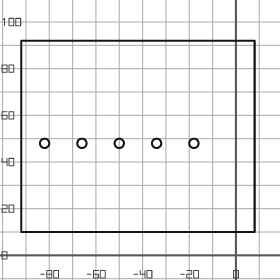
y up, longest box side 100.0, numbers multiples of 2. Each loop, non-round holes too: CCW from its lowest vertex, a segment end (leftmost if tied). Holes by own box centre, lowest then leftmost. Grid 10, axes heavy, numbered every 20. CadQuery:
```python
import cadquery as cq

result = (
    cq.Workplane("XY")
    .moveTo(-92.0, 10.0)
    .lineTo(8.0, 10.0)
    .lineTo(8.0, 92.0)
    .lineTo(-92.0, 92.0)
    .close()
    .moveTo(-82.0, 48.0)
    .circle(2.0)
    .moveTo(-66.0, 48.0)
    .circle(2.0)
    .moveTo(-50.0, 48.0)
    .circle(2.0)
    .moveTo(-34.0, 48.0)
    .circle(2.0)
    .moveTo(-18.0, 48.0)
    .circle(2.0)
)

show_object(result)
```